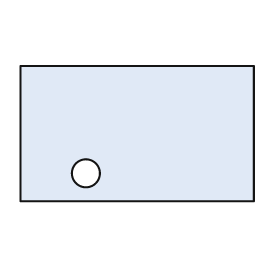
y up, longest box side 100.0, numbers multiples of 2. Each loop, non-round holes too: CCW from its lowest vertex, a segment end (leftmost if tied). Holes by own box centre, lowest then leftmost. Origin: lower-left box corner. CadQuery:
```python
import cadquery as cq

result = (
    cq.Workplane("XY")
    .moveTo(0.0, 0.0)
    .lineTo(100.0, 0.0)
    .lineTo(100.0, 58.0)
    .lineTo(0.0, 58.0)
    .close()
    .moveTo(28.0, 12.0)
    .circle(6.0)
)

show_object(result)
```